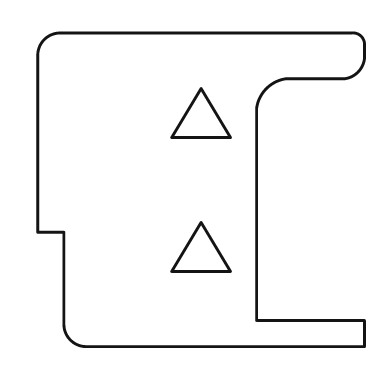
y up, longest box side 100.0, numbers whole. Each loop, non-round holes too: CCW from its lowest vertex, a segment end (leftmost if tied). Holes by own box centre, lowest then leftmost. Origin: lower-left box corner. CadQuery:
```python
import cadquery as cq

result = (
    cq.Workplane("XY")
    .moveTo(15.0, 0.0)
    .lineTo(100.0, 0.0)
    .lineTo(100.0, 8.0)
    .lineTo(67.0, 8.0)
    .lineTo(67.0, 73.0)
    .threePointArc((70.0, 79.0), (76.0, 82.0))
    .lineTo(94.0, 82.0)
    .threePointArc((98.0, 84.0), (100.0, 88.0))
    .lineTo(100.0, 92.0)
    .threePointArc((99.0, 95.0), (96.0, 96.0))
    .lineTo(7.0, 96.0)
    .threePointArc((2.0, 94.0), (0.0, 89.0))
    .lineTo(0.0, 35.0)
    .lineTo(8.0, 35.0)
    .lineTo(8.0, 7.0)
    .threePointArc((10.0, 2.0), (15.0, 0.0))
    .close()
    .moveTo(41.0, 23.0)
    .lineTo(59.0, 23.0)
    .lineTo(50.0, 38.0)
    .close()
    .moveTo(41.0, 64.0)
    .lineTo(59.0, 64.0)
    .lineTo(50.0, 79.0)
    .close()
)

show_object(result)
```